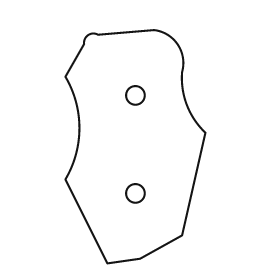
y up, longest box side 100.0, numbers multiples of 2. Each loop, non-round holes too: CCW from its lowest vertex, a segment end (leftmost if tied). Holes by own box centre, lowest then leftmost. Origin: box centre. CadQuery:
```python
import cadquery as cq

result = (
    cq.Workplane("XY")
    .moveTo(-12.0, -50.0)
    .lineTo(2.0, -48.0)
    .lineTo(20.0, -38.0)
    .lineTo(30.0, 6.0)
    .threePointArc((22.0, 18.0), (20.0, 32.0))
    .threePointArc((18.0, 44.0), (8.0, 50.0))
    .lineTo(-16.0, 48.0)
    .threePointArc((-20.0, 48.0), (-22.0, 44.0))
    .lineTo(-30.0, 30.0)
    .threePointArc((-24.0, 8.0), (-30.0, -14.0))
    .close()
    .moveTo(0.0, -20.0)
    .circle(4.0)
    .moveTo(0.0, 22.0)
    .circle(4.0)
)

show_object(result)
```